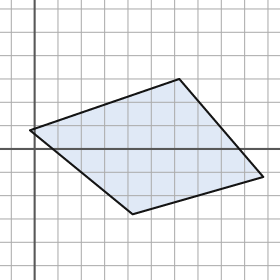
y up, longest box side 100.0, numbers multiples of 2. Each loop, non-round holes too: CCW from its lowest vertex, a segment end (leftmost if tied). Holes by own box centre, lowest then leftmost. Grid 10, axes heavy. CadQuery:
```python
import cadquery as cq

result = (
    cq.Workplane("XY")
    .moveTo(42.0, -28.0)
    .lineTo(98.0, -12.0)
    .lineTo(62.0, 30.0)
    .lineTo(-2.0, 8.0)
    .close()
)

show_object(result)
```